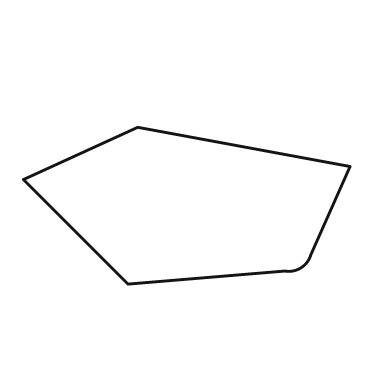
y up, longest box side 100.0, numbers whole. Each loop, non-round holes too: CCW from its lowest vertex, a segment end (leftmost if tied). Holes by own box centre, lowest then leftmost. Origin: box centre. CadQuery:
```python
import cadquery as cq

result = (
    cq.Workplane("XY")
    .moveTo(-18.0, -24.0)
    .lineTo(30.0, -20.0)
    .threePointArc((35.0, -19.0), (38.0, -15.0))
    .lineTo(50.0, 12.0)
    .lineTo(-15.0, 24.0)
    .lineTo(-50.0, 8.0)
    .close()
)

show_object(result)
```